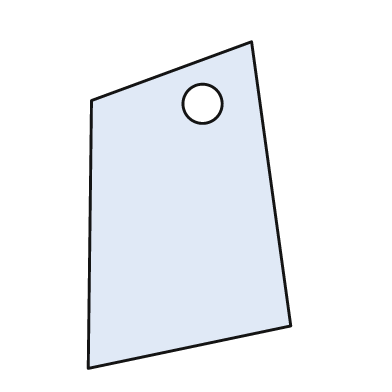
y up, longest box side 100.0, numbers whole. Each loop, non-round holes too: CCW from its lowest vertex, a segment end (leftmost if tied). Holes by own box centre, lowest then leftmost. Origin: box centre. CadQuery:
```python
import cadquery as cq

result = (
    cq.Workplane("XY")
    .moveTo(-31.0, -50.0)
    .lineTo(31.0, -37.0)
    .lineTo(19.0, 50.0)
    .lineTo(-30.0, 32.0)
    .close()
    .moveTo(4.0, 31.0)
    .circle(6.0)
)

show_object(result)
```